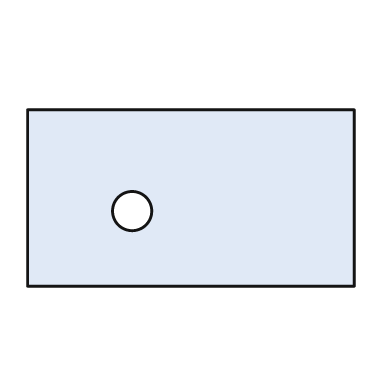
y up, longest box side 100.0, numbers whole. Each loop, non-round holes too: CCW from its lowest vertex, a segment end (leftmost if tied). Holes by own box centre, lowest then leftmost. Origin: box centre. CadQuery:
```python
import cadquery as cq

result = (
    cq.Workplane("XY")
    .moveTo(-50.0, -27.0)
    .lineTo(50.0, -27.0)
    .lineTo(50.0, 27.0)
    .lineTo(-50.0, 27.0)
    .close()
    .moveTo(-18.0, -4.0)
    .circle(6.0)
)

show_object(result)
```